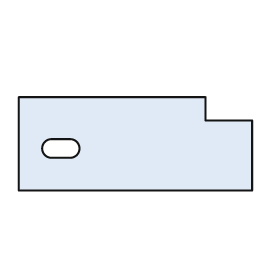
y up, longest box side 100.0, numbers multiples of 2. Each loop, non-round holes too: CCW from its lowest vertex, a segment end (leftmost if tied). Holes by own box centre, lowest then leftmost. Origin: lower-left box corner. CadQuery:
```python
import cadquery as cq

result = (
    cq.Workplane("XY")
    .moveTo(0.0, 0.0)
    .lineTo(100.0, 0.0)
    .lineTo(100.0, 30.0)
    .lineTo(80.0, 30.0)
    .lineTo(80.0, 40.0)
    .lineTo(0.0, 40.0)
    .close()
    .moveTo(14.0, 14.0)
    .lineTo(22.0, 14.0)
    .threePointArc((26.0, 18.0), (22.0, 22.0))
    .lineTo(14.0, 22.0)
    .threePointArc((10.0, 18.0), (14.0, 14.0))
    .close()
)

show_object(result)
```